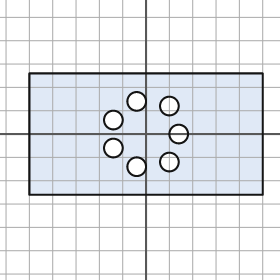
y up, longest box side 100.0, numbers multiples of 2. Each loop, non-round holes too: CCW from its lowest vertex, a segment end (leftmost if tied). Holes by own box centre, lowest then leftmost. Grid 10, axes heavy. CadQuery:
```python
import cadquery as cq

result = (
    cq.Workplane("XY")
    .moveTo(-50.0, -26.0)
    .lineTo(50.0, -26.0)
    .lineTo(50.0, 26.0)
    .lineTo(-50.0, 26.0)
    .close()
    .moveTo(-4.0, -14.0)
    .circle(4.0)
    .moveTo(10.0, -12.0)
    .circle(4.0)
    .moveTo(-14.0, -6.0)
    .circle(4.0)
    .moveTo(14.0, 0.0)
    .circle(4.0)
    .moveTo(-14.0, 6.0)
    .circle(4.0)
    .moveTo(10.0, 12.0)
    .circle(4.0)
    .moveTo(-4.0, 14.0)
    .circle(4.0)
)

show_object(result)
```